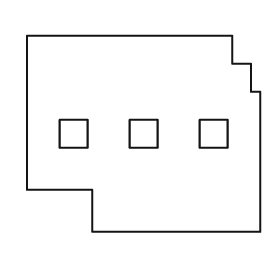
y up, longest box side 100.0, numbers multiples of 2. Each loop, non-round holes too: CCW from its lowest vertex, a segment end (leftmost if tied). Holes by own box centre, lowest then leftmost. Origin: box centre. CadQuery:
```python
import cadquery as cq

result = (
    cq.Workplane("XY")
    .moveTo(-22.0, -42.0)
    .lineTo(50.0, -42.0)
    .lineTo(50.0, 18.0)
    .lineTo(46.0, 18.0)
    .lineTo(46.0, 30.0)
    .lineTo(38.0, 30.0)
    .lineTo(38.0, 42.0)
    .lineTo(-50.0, 42.0)
    .lineTo(-50.0, -24.0)
    .lineTo(-22.0, -24.0)
    .close()
    .moveTo(-36.0, -6.0)
    .lineTo(-24.0, -6.0)
    .lineTo(-24.0, 6.0)
    .lineTo(-36.0, 6.0)
    .close()
    .moveTo(-6.0, -6.0)
    .lineTo(6.0, -6.0)
    .lineTo(6.0, 6.0)
    .lineTo(-6.0, 6.0)
    .close()
    .moveTo(24.0, -6.0)
    .lineTo(36.0, -6.0)
    .lineTo(36.0, 6.0)
    .lineTo(24.0, 6.0)
    .close()
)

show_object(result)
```